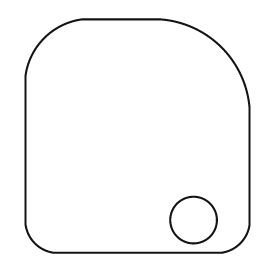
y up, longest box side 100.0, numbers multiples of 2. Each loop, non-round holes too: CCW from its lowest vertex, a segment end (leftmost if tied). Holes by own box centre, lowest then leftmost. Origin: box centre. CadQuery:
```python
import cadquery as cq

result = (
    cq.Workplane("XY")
    .moveTo(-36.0, -50.0)
    .lineTo(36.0, -50.0)
    .threePointArc((44.0, -46.0), (48.0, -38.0))
    .lineTo(48.0, 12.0)
    .threePointArc((36.0, 38.0), (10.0, 50.0))
    .lineTo(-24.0, 50.0)
    .threePointArc((-40.0, 42.0), (-48.0, 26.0))
    .lineTo(-48.0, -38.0)
    .threePointArc((-44.0, -46.0), (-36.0, -50.0))
    .close()
    .moveTo(24.0, -36.0)
    .circle(10.0)
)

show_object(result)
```